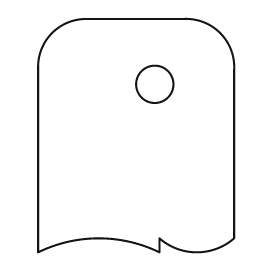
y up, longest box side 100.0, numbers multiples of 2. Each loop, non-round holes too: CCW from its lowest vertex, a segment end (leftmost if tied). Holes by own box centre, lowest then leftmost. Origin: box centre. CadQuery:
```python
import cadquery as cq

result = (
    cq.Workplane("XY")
    .moveTo(-42.0, -50.0)
    .threePointArc((-16.0, -44.0), (10.0, -50.0))
    .lineTo(10.0, -44.0)
    .threePointArc((26.0, -50.0), (42.0, -44.0))
    .lineTo(42.0, 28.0)
    .threePointArc((36.0, 44.0), (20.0, 50.0))
    .lineTo(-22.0, 50.0)
    .threePointArc((-36.0, 44.0), (-42.0, 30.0))
    .close()
    .moveTo(8.0, 22.0)
    .circle(8.0)
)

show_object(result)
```